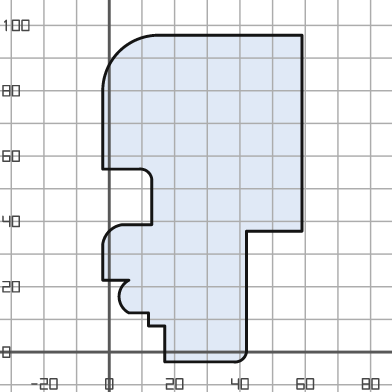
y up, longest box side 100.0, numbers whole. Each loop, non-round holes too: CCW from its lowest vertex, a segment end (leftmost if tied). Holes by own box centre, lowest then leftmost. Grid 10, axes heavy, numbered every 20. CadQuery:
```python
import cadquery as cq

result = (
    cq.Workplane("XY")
    .moveTo(17.0, -3.0)
    .lineTo(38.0, -3.0)
    .threePointArc((41.0, -2.0), (42.0, 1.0))
    .lineTo(42.0, 37.0)
    .lineTo(59.0, 37.0)
    .lineTo(59.0, 97.0)
    .lineTo(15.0, 97.0)
    .threePointArc((3.0, 92.0), (-2.0, 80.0))
    .lineTo(-2.0, 56.0)
    .lineTo(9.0, 56.0)
    .threePointArc((12.0, 55.0), (13.0, 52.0))
    .lineTo(13.0, 39.0)
    .lineTo(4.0, 39.0)
    .threePointArc((0.0, 37.0), (-2.0, 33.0))
    .lineTo(-2.0, 22.0)
    .lineTo(6.0, 22.0)
    .threePointArc((3.0, 17.0), (6.0, 12.0))
    .lineTo(12.0, 12.0)
    .lineTo(12.0, 8.0)
    .lineTo(17.0, 8.0)
    .close()
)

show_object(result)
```